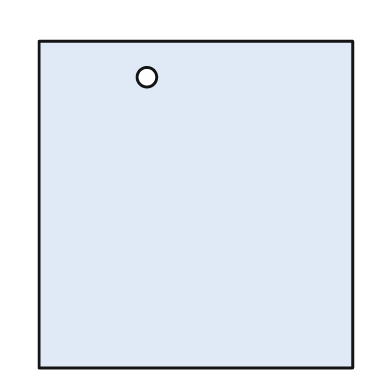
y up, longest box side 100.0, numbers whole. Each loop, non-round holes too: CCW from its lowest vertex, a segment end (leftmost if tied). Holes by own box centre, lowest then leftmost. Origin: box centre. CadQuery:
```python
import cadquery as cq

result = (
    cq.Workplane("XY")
    .moveTo(-48.0, -50.0)
    .lineTo(48.0, -50.0)
    .lineTo(48.0, 50.0)
    .lineTo(-48.0, 50.0)
    .close()
    .moveTo(-15.0, 39.0)
    .circle(3.0)
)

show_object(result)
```